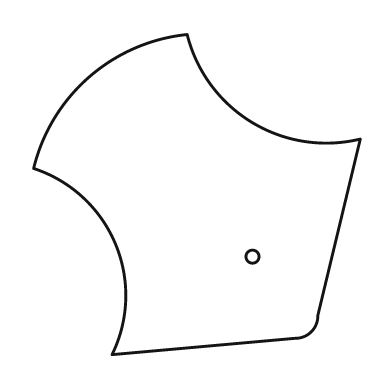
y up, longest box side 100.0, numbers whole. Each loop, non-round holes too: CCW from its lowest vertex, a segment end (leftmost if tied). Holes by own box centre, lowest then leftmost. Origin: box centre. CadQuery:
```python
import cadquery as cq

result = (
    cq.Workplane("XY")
    .moveTo(-26.0, -49.0)
    .lineTo(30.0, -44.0)
    .threePointArc((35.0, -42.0), (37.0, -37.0))
    .lineTo(50.0, 17.0)
    .threePointArc((17.0, 22.0), (-3.0, 49.0))
    .threePointArc((-33.0, 36.0), (-50.0, 8.0))
    .threePointArc((-25.0, -15.0), (-26.0, -49.0))
    .close()
    .moveTo(17.0, -19.0)
    .circle(2.0)
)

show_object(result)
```